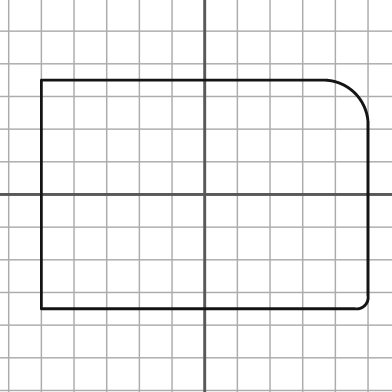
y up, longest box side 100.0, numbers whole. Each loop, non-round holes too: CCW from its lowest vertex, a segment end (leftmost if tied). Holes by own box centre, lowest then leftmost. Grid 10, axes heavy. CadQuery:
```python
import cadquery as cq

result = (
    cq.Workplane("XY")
    .moveTo(-50.0, -35.0)
    .lineTo(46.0, -35.0)
    .threePointArc((49.0, -34.0), (50.0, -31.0))
    .lineTo(50.0, 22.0)
    .threePointArc((46.0, 31.0), (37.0, 35.0))
    .lineTo(-50.0, 35.0)
    .close()
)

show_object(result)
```